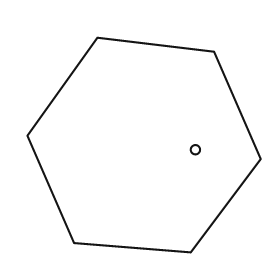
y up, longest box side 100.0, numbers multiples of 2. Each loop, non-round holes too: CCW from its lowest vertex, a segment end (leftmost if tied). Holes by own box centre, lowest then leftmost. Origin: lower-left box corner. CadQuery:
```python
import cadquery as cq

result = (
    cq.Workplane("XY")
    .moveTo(70.0, 0.0)
    .lineTo(100.0, 40.0)
    .lineTo(80.0, 86.0)
    .lineTo(30.0, 92.0)
    .lineTo(0.0, 50.0)
    .lineTo(20.0, 4.0)
    .close()
    .moveTo(72.0, 44.0)
    .circle(2.0)
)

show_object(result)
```